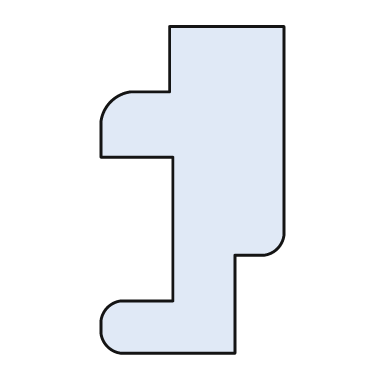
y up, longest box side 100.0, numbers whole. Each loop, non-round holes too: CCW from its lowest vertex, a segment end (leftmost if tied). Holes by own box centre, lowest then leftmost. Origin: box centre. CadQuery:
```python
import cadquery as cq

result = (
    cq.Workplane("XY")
    .moveTo(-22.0, -50.0)
    .lineTo(13.0, -50.0)
    .lineTo(13.0, -20.0)
    .lineTo(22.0, -20.0)
    .threePointArc((26.0, -18.0), (28.0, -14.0))
    .lineTo(28.0, 50.0)
    .lineTo(-7.0, 50.0)
    .lineTo(-7.0, 30.0)
    .lineTo(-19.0, 30.0)
    .threePointArc((-25.0, 27.0), (-28.0, 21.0))
    .lineTo(-28.0, 10.0)
    .lineTo(-6.0, 10.0)
    .lineTo(-6.0, -34.0)
    .lineTo(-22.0, -34.0)
    .threePointArc((-26.0, -36.0), (-28.0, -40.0))
    .lineTo(-28.0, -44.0)
    .threePointArc((-26.0, -48.0), (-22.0, -50.0))
    .close()
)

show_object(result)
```